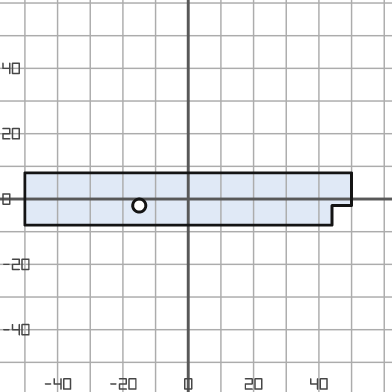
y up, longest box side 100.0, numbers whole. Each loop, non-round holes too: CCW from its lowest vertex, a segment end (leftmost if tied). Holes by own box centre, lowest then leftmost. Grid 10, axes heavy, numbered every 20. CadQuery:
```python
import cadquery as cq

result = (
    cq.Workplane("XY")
    .moveTo(-50.0, -8.0)
    .lineTo(44.0, -8.0)
    .lineTo(44.0, -2.0)
    .lineTo(50.0, -2.0)
    .lineTo(50.0, 8.0)
    .lineTo(-50.0, 8.0)
    .close()
    .moveTo(-15.0, -2.0)
    .circle(2.0)
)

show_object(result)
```